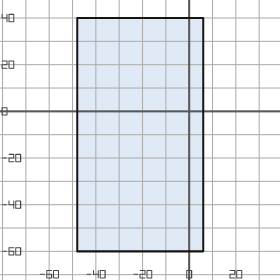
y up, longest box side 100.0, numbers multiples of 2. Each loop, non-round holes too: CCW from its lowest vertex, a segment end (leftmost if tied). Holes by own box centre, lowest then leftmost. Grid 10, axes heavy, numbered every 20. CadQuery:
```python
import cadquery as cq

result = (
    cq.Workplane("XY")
    .moveTo(-48.0, -60.0)
    .lineTo(6.0, -60.0)
    .lineTo(6.0, 40.0)
    .lineTo(-48.0, 40.0)
    .close()
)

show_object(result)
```